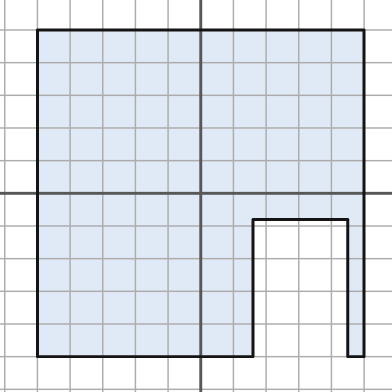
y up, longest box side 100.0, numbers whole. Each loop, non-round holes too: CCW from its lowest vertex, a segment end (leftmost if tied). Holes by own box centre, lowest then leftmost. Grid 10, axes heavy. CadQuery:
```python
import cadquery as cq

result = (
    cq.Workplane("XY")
    .moveTo(-50.0, -50.0)
    .lineTo(16.0, -50.0)
    .lineTo(16.0, -8.0)
    .lineTo(45.0, -8.0)
    .lineTo(45.0, -50.0)
    .lineTo(50.0, -50.0)
    .lineTo(50.0, 50.0)
    .lineTo(-50.0, 50.0)
    .close()
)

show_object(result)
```